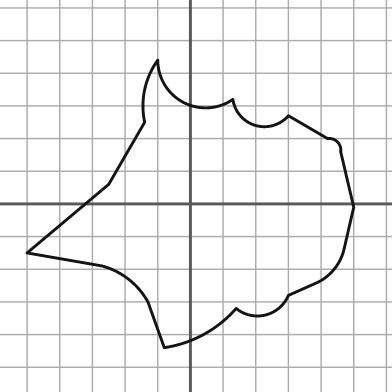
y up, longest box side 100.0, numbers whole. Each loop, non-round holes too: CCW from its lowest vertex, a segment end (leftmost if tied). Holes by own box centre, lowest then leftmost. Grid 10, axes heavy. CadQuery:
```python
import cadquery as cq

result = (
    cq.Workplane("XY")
    .moveTo(-8.0, -44.0)
    .threePointArc((4.0, -40.0), (14.0, -32.0))
    .threePointArc((23.0, -34.0), (30.0, -28.0))
    .lineTo(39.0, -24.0)
    .threePointArc((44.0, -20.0), (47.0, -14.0))
    .lineTo(50.0, -1.0)
    .lineTo(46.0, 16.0)
    .threePointArc((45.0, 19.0), (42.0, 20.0))
    .lineTo(30.0, 27.0)
    .threePointArc((20.0, 24.0), (13.0, 32.0))
    .threePointArc((-2.0, 31.0), (-10.0, 44.0))
    .threePointArc((-14.0, 35.0), (-14.0, 25.0))
    .lineTo(-25.0, 6.0)
    .lineTo(-50.0, -15.0)
    .lineTo(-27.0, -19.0)
    .threePointArc((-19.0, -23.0), (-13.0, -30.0))
    .close()
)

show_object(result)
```